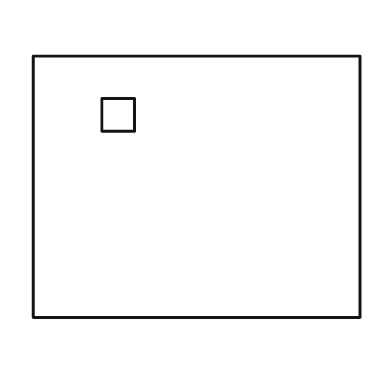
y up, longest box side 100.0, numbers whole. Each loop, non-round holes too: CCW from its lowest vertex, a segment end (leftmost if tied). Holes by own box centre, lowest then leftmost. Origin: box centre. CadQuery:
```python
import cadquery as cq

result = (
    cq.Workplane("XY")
    .moveTo(-50.0, -40.0)
    .lineTo(50.0, -40.0)
    .lineTo(50.0, 40.0)
    .lineTo(-50.0, 40.0)
    .close()
    .moveTo(-29.0, 17.0)
    .lineTo(-19.0, 17.0)
    .lineTo(-19.0, 27.0)
    .lineTo(-29.0, 27.0)
    .close()
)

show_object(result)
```